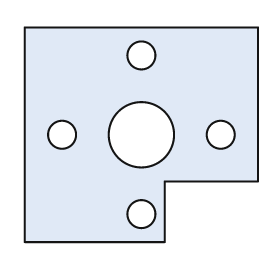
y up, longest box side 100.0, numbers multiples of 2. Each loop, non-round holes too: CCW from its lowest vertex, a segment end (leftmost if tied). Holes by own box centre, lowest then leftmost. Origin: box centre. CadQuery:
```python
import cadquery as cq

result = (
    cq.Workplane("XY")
    .moveTo(-50.0, -46.0)
    .lineTo(10.0, -46.0)
    .lineTo(10.0, -20.0)
    .lineTo(50.0, -20.0)
    .lineTo(50.0, 46.0)
    .lineTo(-50.0, 46.0)
    .close()
    .moveTo(0.0, -34.0)
    .circle(6.0)
    .moveTo(-34.0, 0.0)
    .circle(6.0)
    .moveTo(0.0, 0.0)
    .circle(14.0)
    .moveTo(34.0, 0.0)
    .circle(6.0)
    .moveTo(0.0, 34.0)
    .circle(6.0)
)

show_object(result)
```